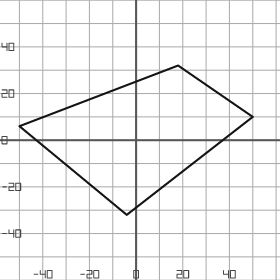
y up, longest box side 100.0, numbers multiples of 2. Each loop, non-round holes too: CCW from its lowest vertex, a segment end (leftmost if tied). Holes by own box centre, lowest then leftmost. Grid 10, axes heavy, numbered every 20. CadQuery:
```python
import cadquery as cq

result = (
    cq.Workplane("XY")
    .moveTo(-4.0, -32.0)
    .lineTo(50.0, 10.0)
    .lineTo(18.0, 32.0)
    .lineTo(-50.0, 6.0)
    .close()
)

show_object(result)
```